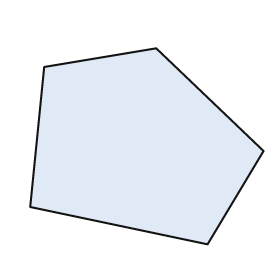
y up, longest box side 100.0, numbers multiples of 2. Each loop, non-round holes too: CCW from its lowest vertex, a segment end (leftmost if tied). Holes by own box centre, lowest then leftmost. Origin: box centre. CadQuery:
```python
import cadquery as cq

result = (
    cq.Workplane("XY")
    .moveTo(26.0, -42.0)
    .lineTo(50.0, -2.0)
    .lineTo(4.0, 42.0)
    .lineTo(-44.0, 34.0)
    .lineTo(-50.0, -26.0)
    .close()
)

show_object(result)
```